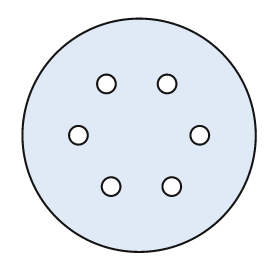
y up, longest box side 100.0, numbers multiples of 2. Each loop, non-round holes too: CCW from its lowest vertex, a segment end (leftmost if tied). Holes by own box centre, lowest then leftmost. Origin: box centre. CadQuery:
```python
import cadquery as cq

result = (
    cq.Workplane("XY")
    .moveTo(0.0, 0.0)
    .circle(50.0)
    .moveTo(-12.0, -22.0)
    .circle(4.0)
    .moveTo(14.0, -22.0)
    .circle(4.0)
    .moveTo(-26.0, 0.0)
    .circle(4.0)
    .moveTo(26.0, 0.0)
    .circle(4.0)
    .moveTo(-14.0, 22.0)
    .circle(4.0)
    .moveTo(12.0, 22.0)
    .circle(4.0)
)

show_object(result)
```